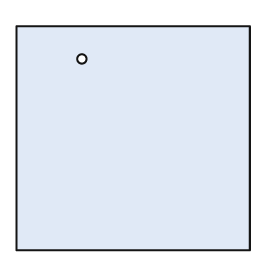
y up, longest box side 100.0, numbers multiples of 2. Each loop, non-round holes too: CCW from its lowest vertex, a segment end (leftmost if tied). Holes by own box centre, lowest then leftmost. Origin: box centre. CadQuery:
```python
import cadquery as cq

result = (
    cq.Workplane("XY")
    .moveTo(-50.0, -48.0)
    .lineTo(50.0, -48.0)
    .lineTo(50.0, 48.0)
    .lineTo(-50.0, 48.0)
    .close()
    .moveTo(-22.0, 34.0)
    .circle(2.0)
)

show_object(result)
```